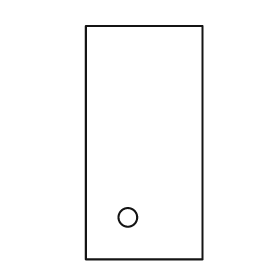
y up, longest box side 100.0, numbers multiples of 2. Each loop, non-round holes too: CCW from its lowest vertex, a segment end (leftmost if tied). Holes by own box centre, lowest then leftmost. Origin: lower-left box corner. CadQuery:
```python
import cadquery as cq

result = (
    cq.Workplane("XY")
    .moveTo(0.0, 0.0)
    .lineTo(50.0, 0.0)
    .lineTo(50.0, 100.0)
    .lineTo(0.0, 100.0)
    .close()
    .moveTo(18.0, 18.0)
    .circle(4.0)
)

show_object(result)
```